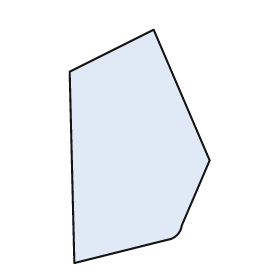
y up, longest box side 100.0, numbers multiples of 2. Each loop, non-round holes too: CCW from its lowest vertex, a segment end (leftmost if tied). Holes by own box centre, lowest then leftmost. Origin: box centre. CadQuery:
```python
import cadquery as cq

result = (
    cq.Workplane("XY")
    .moveTo(-28.0, -50.0)
    .lineTo(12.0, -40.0)
    .threePointArc((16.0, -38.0), (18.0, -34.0))
    .lineTo(30.0, -6.0)
    .lineTo(6.0, 50.0)
    .lineTo(-30.0, 32.0)
    .close()
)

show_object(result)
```